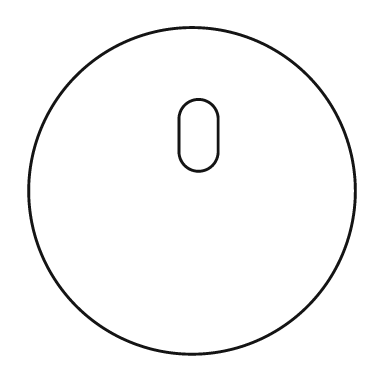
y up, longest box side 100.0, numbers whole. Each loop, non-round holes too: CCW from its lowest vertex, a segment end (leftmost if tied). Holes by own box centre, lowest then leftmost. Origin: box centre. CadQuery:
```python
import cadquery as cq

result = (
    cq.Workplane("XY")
    .moveTo(0.0, 0.0)
    .circle(50.0)
    .moveTo(-4.0, 12.0)
    .threePointArc((2.0, 6.0), (8.0, 12.0))
    .lineTo(8.0, 22.0)
    .threePointArc((2.0, 28.0), (-4.0, 22.0))
    .close()
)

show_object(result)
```